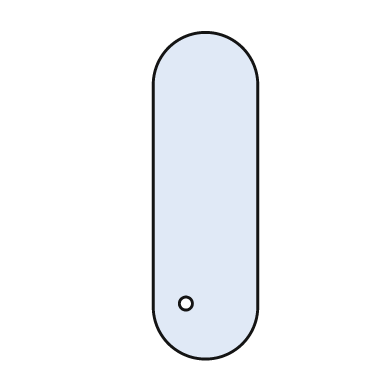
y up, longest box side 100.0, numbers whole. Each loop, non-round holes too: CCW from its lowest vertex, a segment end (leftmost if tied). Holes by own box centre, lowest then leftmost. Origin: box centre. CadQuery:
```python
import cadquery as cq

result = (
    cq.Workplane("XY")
    .moveTo(-16.0, -34.0)
    .threePointArc((0.0, -50.0), (16.0, -34.0))
    .lineTo(16.0, 34.0)
    .threePointArc((0.0, 50.0), (-16.0, 34.0))
    .close()
    .moveTo(-6.0, -33.0)
    .circle(2.0)
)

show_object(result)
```